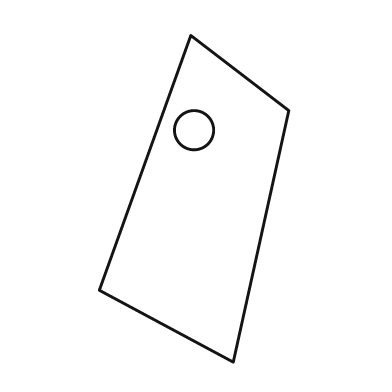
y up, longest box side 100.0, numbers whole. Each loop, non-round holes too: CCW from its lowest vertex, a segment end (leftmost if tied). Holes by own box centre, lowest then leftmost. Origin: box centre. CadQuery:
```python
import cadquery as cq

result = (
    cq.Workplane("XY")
    .moveTo(12.0, -50.0)
    .lineTo(29.0, 27.0)
    .lineTo(-1.0, 50.0)
    .lineTo(-29.0, -28.0)
    .close()
    .moveTo(0.0, 21.0)
    .circle(6.0)
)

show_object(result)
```